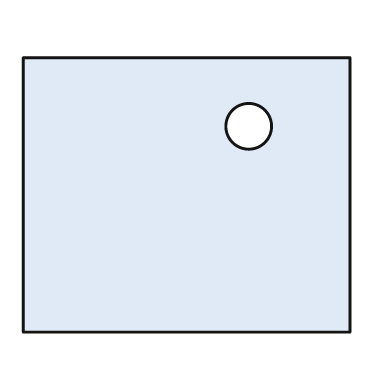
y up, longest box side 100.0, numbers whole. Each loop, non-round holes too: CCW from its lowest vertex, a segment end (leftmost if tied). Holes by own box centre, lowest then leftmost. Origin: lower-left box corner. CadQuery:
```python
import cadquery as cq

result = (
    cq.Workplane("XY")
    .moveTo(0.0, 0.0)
    .lineTo(100.0, 0.0)
    .lineTo(100.0, 84.0)
    .lineTo(0.0, 84.0)
    .close()
    .moveTo(69.0, 63.0)
    .circle(7.0)
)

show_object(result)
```